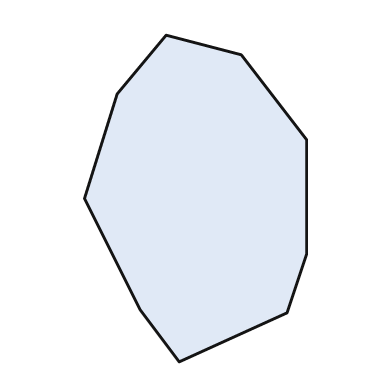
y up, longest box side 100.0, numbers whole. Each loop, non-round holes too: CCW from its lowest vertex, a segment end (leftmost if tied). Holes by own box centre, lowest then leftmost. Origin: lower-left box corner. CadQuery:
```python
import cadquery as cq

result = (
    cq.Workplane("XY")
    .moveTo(29.0, 0.0)
    .lineTo(62.0, 15.0)
    .lineTo(68.0, 33.0)
    .lineTo(68.0, 68.0)
    .lineTo(48.0, 94.0)
    .lineTo(25.0, 100.0)
    .lineTo(10.0, 82.0)
    .lineTo(0.0, 50.0)
    .lineTo(17.0, 16.0)
    .close()
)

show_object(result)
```